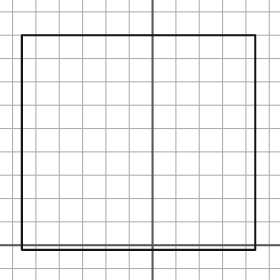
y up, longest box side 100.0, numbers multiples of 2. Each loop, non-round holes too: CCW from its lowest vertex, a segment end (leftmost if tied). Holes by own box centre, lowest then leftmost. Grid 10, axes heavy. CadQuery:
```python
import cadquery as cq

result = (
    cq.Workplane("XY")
    .moveTo(-56.0, -2.0)
    .lineTo(44.0, -2.0)
    .lineTo(44.0, 90.0)
    .lineTo(-56.0, 90.0)
    .close()
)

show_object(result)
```